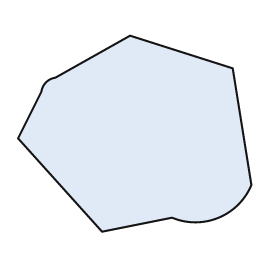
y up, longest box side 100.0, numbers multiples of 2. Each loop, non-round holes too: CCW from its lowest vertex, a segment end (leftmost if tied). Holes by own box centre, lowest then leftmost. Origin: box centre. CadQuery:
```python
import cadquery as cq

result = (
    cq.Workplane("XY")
    .moveTo(-14.0, -42.0)
    .lineTo(16.0, -36.0)
    .threePointArc((36.0, -36.0), (50.0, -22.0))
    .lineTo(42.0, 28.0)
    .lineTo(-2.0, 42.0)
    .lineTo(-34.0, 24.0)
    .threePointArc((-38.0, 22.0), (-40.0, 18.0))
    .lineTo(-50.0, -2.0)
    .close()
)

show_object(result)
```